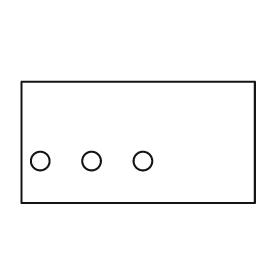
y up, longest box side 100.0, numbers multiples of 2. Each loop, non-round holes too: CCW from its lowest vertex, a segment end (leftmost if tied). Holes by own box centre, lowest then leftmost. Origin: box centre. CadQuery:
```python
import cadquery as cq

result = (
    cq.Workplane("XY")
    .moveTo(-50.0, -26.0)
    .lineTo(50.0, -26.0)
    .lineTo(50.0, 26.0)
    .lineTo(-50.0, 26.0)
    .close()
    .moveTo(-42.0, -8.0)
    .circle(4.0)
    .moveTo(-20.0, -8.0)
    .circle(4.0)
    .moveTo(2.0, -8.0)
    .circle(4.0)
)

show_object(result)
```